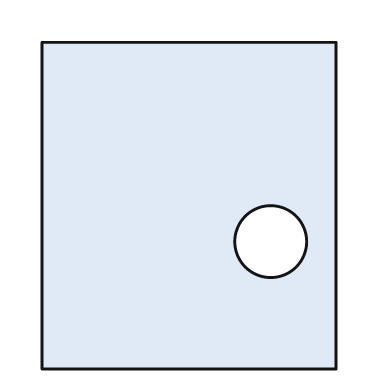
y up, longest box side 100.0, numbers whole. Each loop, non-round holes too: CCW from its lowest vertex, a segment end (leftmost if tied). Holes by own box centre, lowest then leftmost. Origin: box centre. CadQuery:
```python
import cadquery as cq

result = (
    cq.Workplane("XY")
    .moveTo(-45.0, -50.0)
    .lineTo(45.0, -50.0)
    .lineTo(45.0, 50.0)
    .lineTo(-45.0, 50.0)
    .close()
    .moveTo(25.0, -11.0)
    .circle(11.0)
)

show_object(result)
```